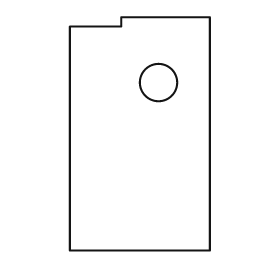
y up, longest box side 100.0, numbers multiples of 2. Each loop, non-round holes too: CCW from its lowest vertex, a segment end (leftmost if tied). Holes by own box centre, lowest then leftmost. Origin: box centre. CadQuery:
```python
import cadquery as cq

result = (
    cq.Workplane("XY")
    .moveTo(-30.0, -50.0)
    .lineTo(30.0, -50.0)
    .lineTo(30.0, 50.0)
    .lineTo(-8.0, 50.0)
    .lineTo(-8.0, 46.0)
    .lineTo(-30.0, 46.0)
    .close()
    .moveTo(8.0, 22.0)
    .circle(8.0)
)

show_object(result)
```